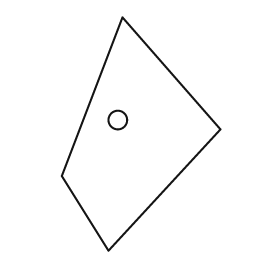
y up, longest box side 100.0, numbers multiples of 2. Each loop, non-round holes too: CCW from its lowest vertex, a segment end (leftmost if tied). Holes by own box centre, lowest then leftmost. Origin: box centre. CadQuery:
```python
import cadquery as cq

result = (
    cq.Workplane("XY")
    .moveTo(-14.0, -50.0)
    .lineTo(34.0, 2.0)
    .lineTo(-8.0, 50.0)
    .lineTo(-34.0, -18.0)
    .close()
    .moveTo(-10.0, 6.0)
    .circle(4.0)
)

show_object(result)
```